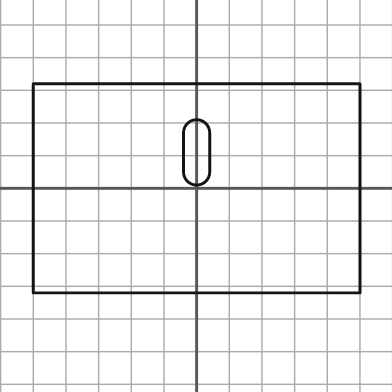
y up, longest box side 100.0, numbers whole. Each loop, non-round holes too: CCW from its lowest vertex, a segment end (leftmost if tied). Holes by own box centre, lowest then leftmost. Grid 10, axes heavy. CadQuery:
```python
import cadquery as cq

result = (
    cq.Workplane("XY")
    .moveTo(-50.0, -32.0)
    .lineTo(50.0, -32.0)
    .lineTo(50.0, 32.0)
    .lineTo(-50.0, 32.0)
    .close()
    .moveTo(-4.0, 5.0)
    .threePointArc((0.0, 1.0), (4.0, 5.0))
    .lineTo(4.0, 17.0)
    .threePointArc((0.0, 21.0), (-4.0, 17.0))
    .close()
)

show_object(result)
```